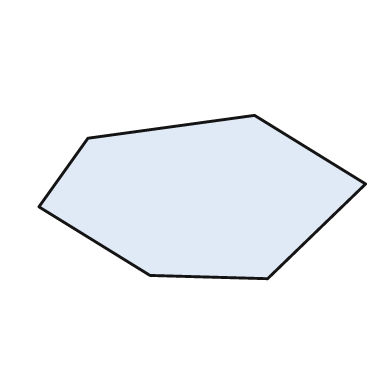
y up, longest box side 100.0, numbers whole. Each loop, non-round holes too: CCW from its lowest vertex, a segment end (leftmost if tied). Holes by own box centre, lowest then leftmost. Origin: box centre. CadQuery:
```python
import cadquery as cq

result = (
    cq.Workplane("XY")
    .moveTo(20.0, -25.0)
    .lineTo(50.0, 4.0)
    .lineTo(16.0, 25.0)
    .lineTo(-35.0, 18.0)
    .lineTo(-50.0, -3.0)
    .lineTo(-16.0, -24.0)
    .close()
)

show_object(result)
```